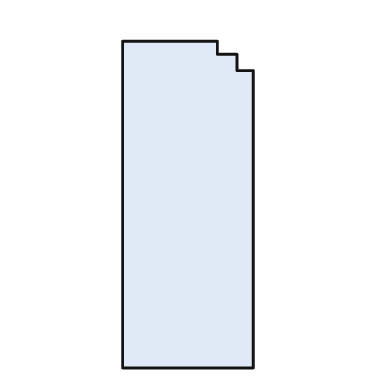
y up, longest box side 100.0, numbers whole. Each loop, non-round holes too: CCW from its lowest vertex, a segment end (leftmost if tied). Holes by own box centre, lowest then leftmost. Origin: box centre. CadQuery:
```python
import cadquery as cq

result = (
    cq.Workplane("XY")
    .moveTo(-20.0, -50.0)
    .lineTo(20.0, -50.0)
    .lineTo(20.0, 41.0)
    .lineTo(15.0, 41.0)
    .lineTo(15.0, 46.0)
    .lineTo(9.0, 46.0)
    .lineTo(9.0, 50.0)
    .lineTo(-20.0, 50.0)
    .close()
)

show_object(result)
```